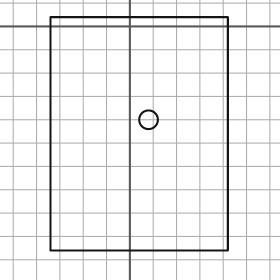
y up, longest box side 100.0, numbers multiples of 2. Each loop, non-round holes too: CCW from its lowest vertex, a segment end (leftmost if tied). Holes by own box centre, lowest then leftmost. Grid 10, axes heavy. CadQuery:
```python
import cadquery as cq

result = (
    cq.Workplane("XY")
    .moveTo(-34.0, -96.0)
    .lineTo(42.0, -96.0)
    .lineTo(42.0, 4.0)
    .lineTo(-34.0, 4.0)
    .close()
    .moveTo(8.0, -40.0)
    .circle(4.0)
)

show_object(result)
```